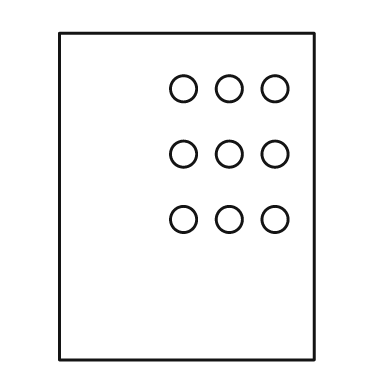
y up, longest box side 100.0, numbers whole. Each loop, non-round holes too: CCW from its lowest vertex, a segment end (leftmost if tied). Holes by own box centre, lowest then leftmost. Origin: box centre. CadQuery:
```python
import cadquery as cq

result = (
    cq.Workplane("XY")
    .moveTo(-39.0, -50.0)
    .lineTo(39.0, -50.0)
    .lineTo(39.0, 50.0)
    .lineTo(-39.0, 50.0)
    .close()
    .moveTo(-1.0, -7.0)
    .circle(4.0)
    .moveTo(13.0, -7.0)
    .circle(4.0)
    .moveTo(27.0, -7.0)
    .circle(4.0)
    .moveTo(-1.0, 13.0)
    .circle(4.0)
    .moveTo(13.0, 13.0)
    .circle(4.0)
    .moveTo(27.0, 13.0)
    .circle(4.0)
    .moveTo(-1.0, 33.0)
    .circle(4.0)
    .moveTo(13.0, 33.0)
    .circle(4.0)
    .moveTo(27.0, 33.0)
    .circle(4.0)
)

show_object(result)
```